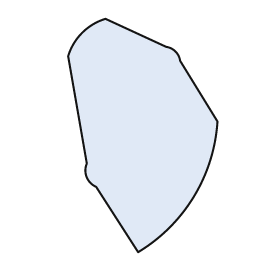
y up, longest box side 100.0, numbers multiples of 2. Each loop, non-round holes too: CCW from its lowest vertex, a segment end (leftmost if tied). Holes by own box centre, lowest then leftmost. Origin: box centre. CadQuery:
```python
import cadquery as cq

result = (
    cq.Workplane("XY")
    .moveTo(-2.0, -50.0)
    .threePointArc((22.0, -26.0), (32.0, 6.0))
    .lineTo(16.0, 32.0)
    .threePointArc((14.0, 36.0), (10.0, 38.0))
    .lineTo(-16.0, 50.0)
    .threePointArc((-26.0, 44.0), (-32.0, 34.0))
    .lineTo(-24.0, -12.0)
    .threePointArc((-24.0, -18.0), (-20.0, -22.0))
    .close()
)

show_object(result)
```